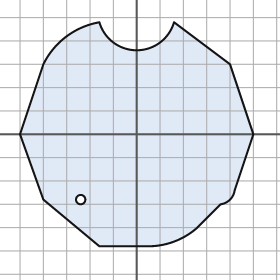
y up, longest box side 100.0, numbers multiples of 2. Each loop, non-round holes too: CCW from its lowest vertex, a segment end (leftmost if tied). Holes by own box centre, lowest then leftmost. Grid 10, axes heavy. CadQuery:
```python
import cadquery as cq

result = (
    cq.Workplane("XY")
    .moveTo(-16.0, -48.0)
    .lineTo(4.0, -48.0)
    .threePointArc((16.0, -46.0), (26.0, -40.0))
    .lineTo(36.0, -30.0)
    .threePointArc((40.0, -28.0), (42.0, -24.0))
    .lineTo(50.0, 0.0)
    .lineTo(40.0, 30.0)
    .lineTo(16.0, 48.0)
    .threePointArc((0.0, 36.0), (-16.0, 48.0))
    .threePointArc((-30.0, 42.0), (-40.0, 30.0))
    .lineTo(-50.0, 0.0)
    .lineTo(-40.0, -28.0)
    .close()
    .moveTo(-24.0, -28.0)
    .circle(2.0)
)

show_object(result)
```